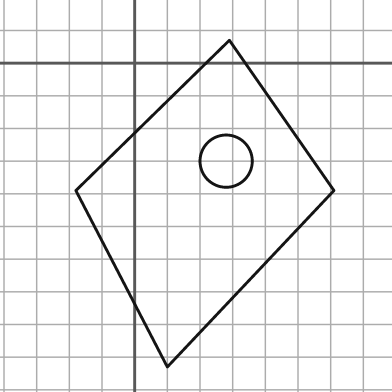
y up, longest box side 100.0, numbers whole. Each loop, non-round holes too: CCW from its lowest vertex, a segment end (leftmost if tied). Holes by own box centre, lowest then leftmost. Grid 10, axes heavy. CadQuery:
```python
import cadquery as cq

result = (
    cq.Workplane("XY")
    .moveTo(10.0, -93.0)
    .lineTo(61.0, -39.0)
    .lineTo(29.0, 7.0)
    .lineTo(-18.0, -39.0)
    .close()
    .moveTo(28.0, -30.0)
    .circle(8.0)
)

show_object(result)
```